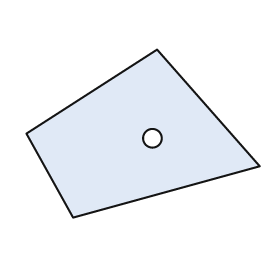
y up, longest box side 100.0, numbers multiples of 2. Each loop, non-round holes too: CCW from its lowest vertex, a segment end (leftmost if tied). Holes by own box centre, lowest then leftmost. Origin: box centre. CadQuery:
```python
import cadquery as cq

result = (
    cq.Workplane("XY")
    .moveTo(-30.0, -36.0)
    .lineTo(50.0, -14.0)
    .lineTo(6.0, 36.0)
    .lineTo(-50.0, 0.0)
    .close()
    .moveTo(4.0, -2.0)
    .circle(4.0)
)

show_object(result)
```